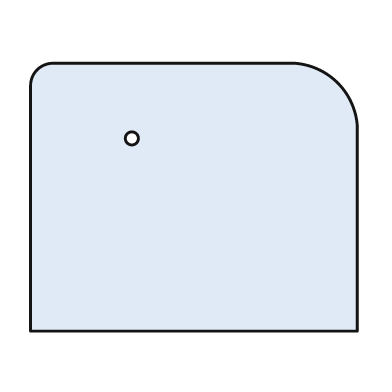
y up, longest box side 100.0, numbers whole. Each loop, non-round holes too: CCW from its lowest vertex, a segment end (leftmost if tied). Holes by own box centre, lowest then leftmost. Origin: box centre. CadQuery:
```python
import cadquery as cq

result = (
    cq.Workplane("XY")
    .moveTo(-50.0, -41.0)
    .lineTo(50.0, -41.0)
    .lineTo(50.0, 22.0)
    .threePointArc((44.0, 35.0), (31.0, 41.0))
    .lineTo(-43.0, 41.0)
    .threePointArc((-48.0, 39.0), (-50.0, 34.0))
    .close()
    .moveTo(-19.0, 18.0)
    .circle(2.0)
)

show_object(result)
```